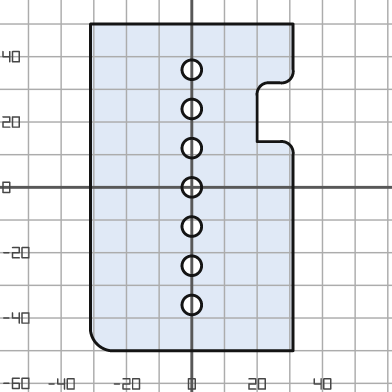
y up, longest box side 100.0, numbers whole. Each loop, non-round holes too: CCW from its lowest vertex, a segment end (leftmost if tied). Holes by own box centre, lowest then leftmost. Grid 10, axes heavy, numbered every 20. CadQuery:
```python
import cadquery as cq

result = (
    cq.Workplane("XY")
    .moveTo(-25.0, -50.0)
    .lineTo(31.0, -50.0)
    .lineTo(31.0, 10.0)
    .threePointArc((30.0, 13.0), (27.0, 14.0))
    .lineTo(20.0, 14.0)
    .lineTo(20.0, 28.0)
    .threePointArc((21.0, 31.0), (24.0, 32.0))
    .lineTo(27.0, 32.0)
    .threePointArc((30.0, 33.0), (31.0, 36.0))
    .lineTo(31.0, 50.0)
    .lineTo(-31.0, 50.0)
    .lineTo(-31.0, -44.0)
    .threePointArc((-29.0, -48.0), (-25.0, -50.0))
    .close()
    .moveTo(0.0, -36.0)
    .circle(3.0)
    .moveTo(0.0, -24.0)
    .circle(3.0)
    .moveTo(0.0, -12.0)
    .circle(3.0)
    .moveTo(0.0, 0.0)
    .circle(3.0)
    .moveTo(0.0, 12.0)
    .circle(3.0)
    .moveTo(0.0, 24.0)
    .circle(3.0)
    .moveTo(0.0, 36.0)
    .circle(3.0)
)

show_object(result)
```